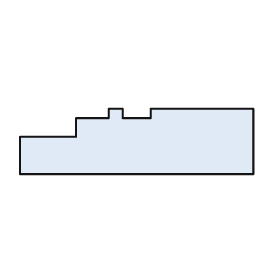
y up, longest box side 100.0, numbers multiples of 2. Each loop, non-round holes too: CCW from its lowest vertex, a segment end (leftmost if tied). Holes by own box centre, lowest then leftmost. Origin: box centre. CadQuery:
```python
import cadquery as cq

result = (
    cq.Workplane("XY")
    .moveTo(-50.0, -14.0)
    .lineTo(50.0, -14.0)
    .lineTo(50.0, 14.0)
    .lineTo(6.0, 14.0)
    .lineTo(6.0, 10.0)
    .lineTo(-6.0, 10.0)
    .lineTo(-6.0, 14.0)
    .lineTo(-12.0, 14.0)
    .lineTo(-12.0, 10.0)
    .lineTo(-26.0, 10.0)
    .lineTo(-26.0, 2.0)
    .lineTo(-50.0, 2.0)
    .close()
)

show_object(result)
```